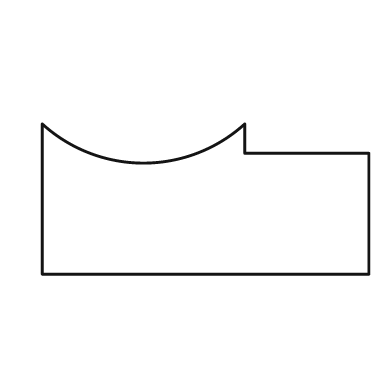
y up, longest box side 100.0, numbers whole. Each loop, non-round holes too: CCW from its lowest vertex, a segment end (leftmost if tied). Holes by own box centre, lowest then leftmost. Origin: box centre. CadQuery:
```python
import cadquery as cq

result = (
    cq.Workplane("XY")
    .moveTo(-50.0, -23.0)
    .lineTo(50.0, -23.0)
    .lineTo(50.0, 14.0)
    .lineTo(12.0, 14.0)
    .lineTo(12.0, 23.0)
    .threePointArc((-19.0, 11.0), (-50.0, 23.0))
    .close()
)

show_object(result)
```